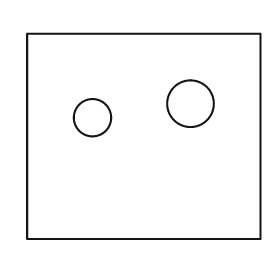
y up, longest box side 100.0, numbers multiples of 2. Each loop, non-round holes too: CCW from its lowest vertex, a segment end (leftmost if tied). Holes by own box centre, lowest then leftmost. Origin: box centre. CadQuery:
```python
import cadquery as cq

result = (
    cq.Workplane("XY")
    .moveTo(-50.0, -44.0)
    .lineTo(50.0, -44.0)
    .lineTo(50.0, 44.0)
    .lineTo(-50.0, 44.0)
    .close()
    .moveTo(-22.0, 8.0)
    .circle(8.0)
    .moveTo(20.0, 14.0)
    .circle(10.0)
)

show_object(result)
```